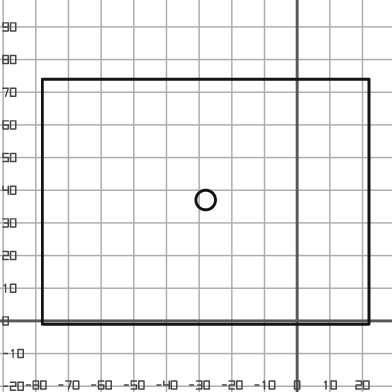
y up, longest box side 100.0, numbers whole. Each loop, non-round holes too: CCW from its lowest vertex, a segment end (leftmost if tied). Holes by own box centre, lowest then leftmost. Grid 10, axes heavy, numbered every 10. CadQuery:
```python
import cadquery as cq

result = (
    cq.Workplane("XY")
    .moveTo(-78.0, -1.0)
    .lineTo(22.0, -1.0)
    .lineTo(22.0, 74.0)
    .lineTo(-78.0, 74.0)
    .close()
    .moveTo(-28.0, 37.0)
    .circle(3.0)
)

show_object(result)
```